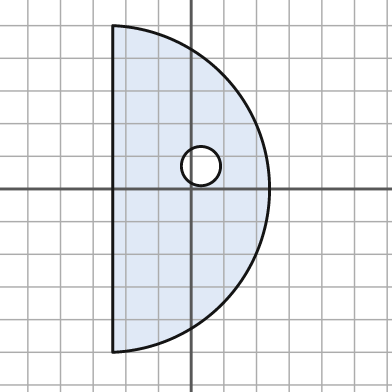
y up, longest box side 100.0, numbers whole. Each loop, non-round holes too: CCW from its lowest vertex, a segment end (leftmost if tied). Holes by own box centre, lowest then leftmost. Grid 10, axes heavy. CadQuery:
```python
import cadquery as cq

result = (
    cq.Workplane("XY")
    .moveTo(-24.0, -50.0)
    .threePointArc((24.0, 0.0), (-24.0, 50.0))
    .close()
    .moveTo(3.0, 7.0)
    .circle(6.0)
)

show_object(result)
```